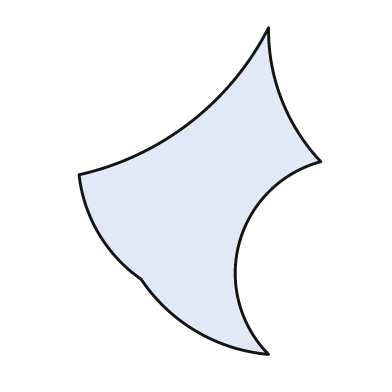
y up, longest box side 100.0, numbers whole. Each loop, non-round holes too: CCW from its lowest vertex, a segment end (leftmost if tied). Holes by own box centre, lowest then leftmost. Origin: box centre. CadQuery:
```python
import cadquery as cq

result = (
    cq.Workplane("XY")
    .moveTo(21.0, -50.0)
    .threePointArc((12.0, -16.0), (37.0, 9.0))
    .threePointArc((25.0, 28.0), (21.0, 50.0))
    .threePointArc((-3.0, 21.0), (-37.0, 5.0))
    .threePointArc((-31.0, -13.0), (-18.0, -27.0))
    .threePointArc((-1.0, -43.0), (21.0, -50.0))
    .close()
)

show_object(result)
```